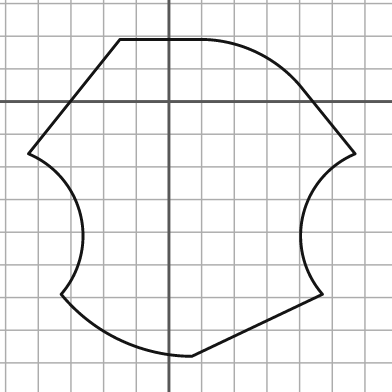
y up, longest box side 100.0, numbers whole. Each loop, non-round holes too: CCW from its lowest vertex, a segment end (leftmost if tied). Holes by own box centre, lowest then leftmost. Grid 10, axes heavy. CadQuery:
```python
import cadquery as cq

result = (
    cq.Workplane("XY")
    .moveTo(7.0, -78.0)
    .lineTo(47.0, -59.0)
    .threePointArc((41.0, -35.0), (57.0, -16.0))
    .lineTo(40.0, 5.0)
    .threePointArc((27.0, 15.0), (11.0, 19.0))
    .lineTo(-15.0, 19.0)
    .lineTo(-43.0, -16.0)
    .threePointArc((-27.0, -35.0), (-33.0, -59.0))
    .threePointArc((-15.0, -73.0), (7.0, -78.0))
    .close()
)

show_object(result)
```